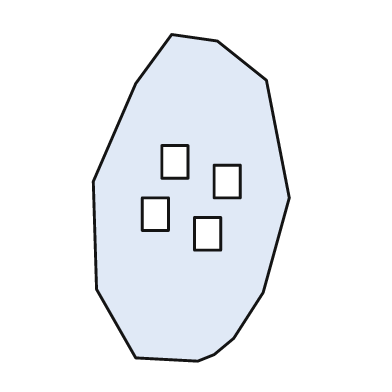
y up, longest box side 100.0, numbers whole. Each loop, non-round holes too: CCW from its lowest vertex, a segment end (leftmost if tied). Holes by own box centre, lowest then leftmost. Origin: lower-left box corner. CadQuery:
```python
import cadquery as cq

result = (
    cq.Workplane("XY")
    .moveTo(32.0, 0.0)
    .lineTo(37.0, 2.0)
    .lineTo(43.0, 7.0)
    .lineTo(52.0, 21.0)
    .lineTo(60.0, 50.0)
    .lineTo(53.0, 86.0)
    .lineTo(38.0, 98.0)
    .lineTo(24.0, 100.0)
    .lineTo(13.0, 85.0)
    .lineTo(0.0, 55.0)
    .lineTo(1.0, 22.0)
    .lineTo(13.0, 1.0)
    .close()
    .moveTo(31.0, 34.0)
    .lineTo(39.0, 34.0)
    .lineTo(39.0, 44.0)
    .lineTo(31.0, 44.0)
    .close()
    .moveTo(15.0, 40.0)
    .lineTo(23.0, 40.0)
    .lineTo(23.0, 50.0)
    .lineTo(15.0, 50.0)
    .close()
    .moveTo(37.0, 50.0)
    .lineTo(45.0, 50.0)
    .lineTo(45.0, 60.0)
    .lineTo(37.0, 60.0)
    .close()
    .moveTo(21.0, 56.0)
    .lineTo(29.0, 56.0)
    .lineTo(29.0, 66.0)
    .lineTo(21.0, 66.0)
    .close()
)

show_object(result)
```